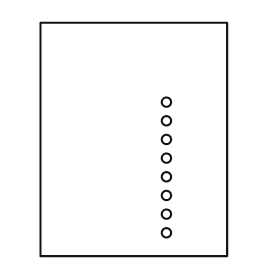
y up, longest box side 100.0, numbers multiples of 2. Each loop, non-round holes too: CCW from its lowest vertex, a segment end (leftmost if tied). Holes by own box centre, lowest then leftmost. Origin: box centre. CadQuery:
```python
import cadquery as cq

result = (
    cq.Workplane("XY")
    .moveTo(-40.0, -50.0)
    .lineTo(40.0, -50.0)
    .lineTo(40.0, 50.0)
    .lineTo(-40.0, 50.0)
    .close()
    .moveTo(14.0, -40.0)
    .circle(2.0)
    .moveTo(14.0, -32.0)
    .circle(2.0)
    .moveTo(14.0, -24.0)
    .circle(2.0)
    .moveTo(14.0, -16.0)
    .circle(2.0)
    .moveTo(14.0, -8.0)
    .circle(2.0)
    .moveTo(14.0, 0.0)
    .circle(2.0)
    .moveTo(14.0, 8.0)
    .circle(2.0)
    .moveTo(14.0, 16.0)
    .circle(2.0)
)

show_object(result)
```